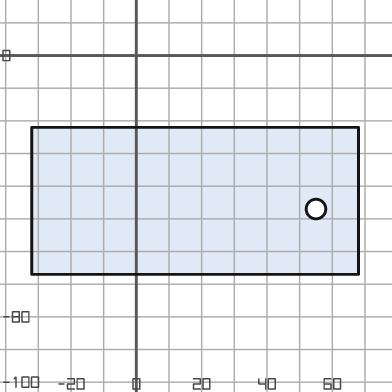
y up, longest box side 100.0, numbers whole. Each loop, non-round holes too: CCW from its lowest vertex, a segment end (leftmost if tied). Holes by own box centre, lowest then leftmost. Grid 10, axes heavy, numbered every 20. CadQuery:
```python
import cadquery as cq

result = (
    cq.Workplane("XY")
    .moveTo(-32.0, -67.0)
    .lineTo(68.0, -67.0)
    .lineTo(68.0, -22.0)
    .lineTo(-32.0, -22.0)
    .close()
    .moveTo(55.0, -47.0)
    .circle(3.0)
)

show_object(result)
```